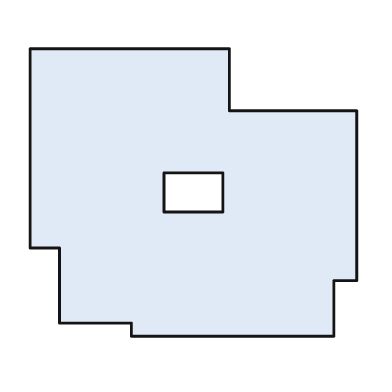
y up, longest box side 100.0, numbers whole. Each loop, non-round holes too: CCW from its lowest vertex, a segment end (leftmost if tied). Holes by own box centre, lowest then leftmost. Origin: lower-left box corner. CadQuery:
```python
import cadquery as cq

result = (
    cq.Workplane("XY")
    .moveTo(31.0, 0.0)
    .lineTo(93.0, 0.0)
    .lineTo(93.0, 17.0)
    .lineTo(100.0, 17.0)
    .lineTo(100.0, 69.0)
    .lineTo(61.0, 69.0)
    .lineTo(61.0, 88.0)
    .lineTo(0.0, 88.0)
    .lineTo(0.0, 27.0)
    .lineTo(9.0, 27.0)
    .lineTo(9.0, 4.0)
    .lineTo(31.0, 4.0)
    .close()
    .moveTo(41.0, 38.0)
    .lineTo(59.0, 38.0)
    .lineTo(59.0, 50.0)
    .lineTo(41.0, 50.0)
    .close()
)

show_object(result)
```